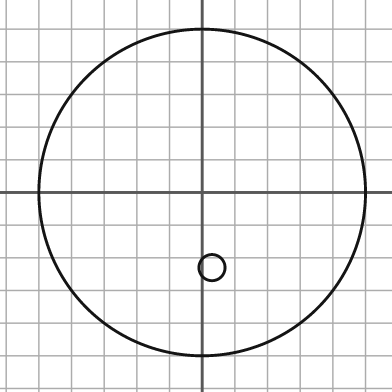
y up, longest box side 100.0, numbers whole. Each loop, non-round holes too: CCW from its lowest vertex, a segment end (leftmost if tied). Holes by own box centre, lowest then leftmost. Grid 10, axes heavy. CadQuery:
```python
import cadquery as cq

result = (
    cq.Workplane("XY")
    .moveTo(0.0, 0.0)
    .circle(50.0)
    .moveTo(3.0, -23.0)
    .circle(4.0)
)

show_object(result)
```